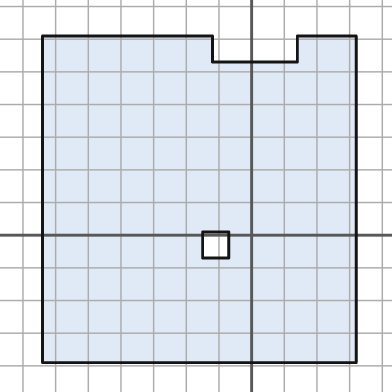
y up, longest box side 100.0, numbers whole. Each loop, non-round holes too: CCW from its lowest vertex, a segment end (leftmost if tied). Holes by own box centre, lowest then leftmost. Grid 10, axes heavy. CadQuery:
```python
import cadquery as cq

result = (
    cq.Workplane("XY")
    .moveTo(-64.0, -39.0)
    .lineTo(32.0, -39.0)
    .lineTo(32.0, 61.0)
    .lineTo(14.0, 61.0)
    .lineTo(14.0, 53.0)
    .lineTo(-12.0, 53.0)
    .lineTo(-12.0, 61.0)
    .lineTo(-64.0, 61.0)
    .close()
    .moveTo(-15.0, -7.0)
    .lineTo(-7.0, -7.0)
    .lineTo(-7.0, 1.0)
    .lineTo(-15.0, 1.0)
    .close()
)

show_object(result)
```